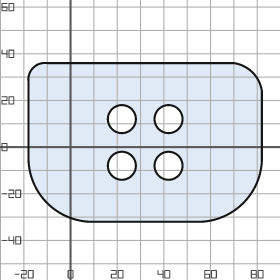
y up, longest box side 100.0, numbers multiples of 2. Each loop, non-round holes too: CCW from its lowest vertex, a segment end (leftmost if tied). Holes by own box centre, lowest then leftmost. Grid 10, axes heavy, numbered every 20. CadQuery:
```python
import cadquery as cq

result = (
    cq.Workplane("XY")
    .moveTo(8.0, -32.0)
    .lineTo(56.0, -32.0)
    .threePointArc((74.0, -24.0), (82.0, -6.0))
    .lineTo(82.0, 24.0)
    .threePointArc((78.0, 32.0), (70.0, 36.0))
    .lineTo(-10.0, 36.0)
    .threePointArc((-16.0, 34.0), (-18.0, 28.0))
    .lineTo(-18.0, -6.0)
    .threePointArc((-10.0, -24.0), (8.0, -32.0))
    .close()
    .moveTo(22.0, -8.0)
    .circle(6.0)
    .moveTo(42.0, -8.0)
    .circle(6.0)
    .moveTo(22.0, 12.0)
    .circle(6.0)
    .moveTo(42.0, 12.0)
    .circle(6.0)
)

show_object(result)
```